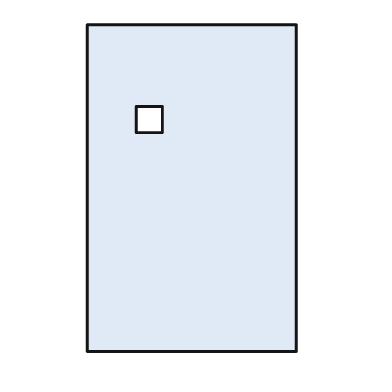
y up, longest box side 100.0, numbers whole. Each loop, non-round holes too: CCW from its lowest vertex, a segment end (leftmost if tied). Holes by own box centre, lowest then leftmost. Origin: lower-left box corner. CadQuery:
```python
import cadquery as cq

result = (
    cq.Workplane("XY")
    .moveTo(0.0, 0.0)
    .lineTo(64.0, 0.0)
    .lineTo(64.0, 100.0)
    .lineTo(0.0, 100.0)
    .close()
    .moveTo(15.0, 67.0)
    .lineTo(23.0, 67.0)
    .lineTo(23.0, 75.0)
    .lineTo(15.0, 75.0)
    .close()
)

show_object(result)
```